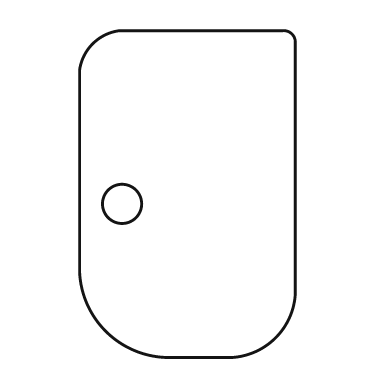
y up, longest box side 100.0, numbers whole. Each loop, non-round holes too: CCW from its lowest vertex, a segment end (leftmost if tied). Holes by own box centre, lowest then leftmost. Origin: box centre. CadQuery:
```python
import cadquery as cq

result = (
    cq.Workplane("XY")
    .moveTo(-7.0, -50.0)
    .lineTo(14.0, -50.0)
    .threePointArc((27.0, -44.0), (33.0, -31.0))
    .lineTo(33.0, 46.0)
    .threePointArc((32.0, 49.0), (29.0, 50.0))
    .lineTo(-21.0, 50.0)
    .threePointArc((-29.0, 46.0), (-33.0, 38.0))
    .lineTo(-33.0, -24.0)
    .threePointArc((-25.0, -42.0), (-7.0, -50.0))
    .close()
    .moveTo(-20.0, -3.0)
    .circle(6.0)
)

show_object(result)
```